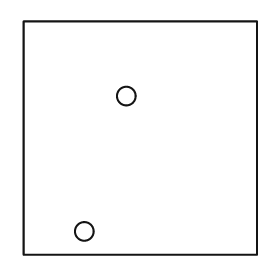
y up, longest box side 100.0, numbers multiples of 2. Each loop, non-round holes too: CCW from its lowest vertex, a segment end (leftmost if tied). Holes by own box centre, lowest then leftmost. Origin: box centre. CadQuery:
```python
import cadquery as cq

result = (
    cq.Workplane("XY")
    .moveTo(-50.0, -50.0)
    .lineTo(50.0, -50.0)
    .lineTo(50.0, 50.0)
    .lineTo(-50.0, 50.0)
    .close()
    .moveTo(-24.0, -40.0)
    .circle(4.0)
    .moveTo(-6.0, 18.0)
    .circle(4.0)
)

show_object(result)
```